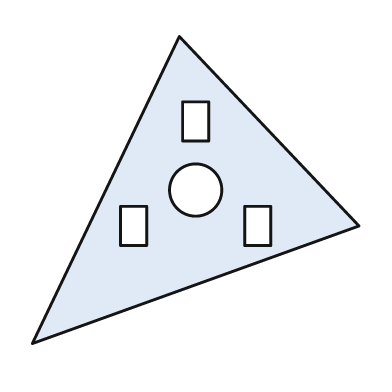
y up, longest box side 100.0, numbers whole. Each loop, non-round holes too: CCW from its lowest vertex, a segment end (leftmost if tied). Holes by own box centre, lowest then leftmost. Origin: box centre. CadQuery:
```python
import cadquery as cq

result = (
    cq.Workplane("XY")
    .moveTo(-50.0, -47.0)
    .lineTo(50.0, -11.0)
    .lineTo(-5.0, 47.0)
    .close()
    .moveTo(-23.0, -17.0)
    .lineTo(-15.0, -17.0)
    .lineTo(-15.0, -5.0)
    .lineTo(-23.0, -5.0)
    .close()
    .moveTo(15.0, -17.0)
    .lineTo(23.0, -17.0)
    .lineTo(23.0, -5.0)
    .lineTo(15.0, -5.0)
    .close()
    .moveTo(0.0, 0.0)
    .circle(8.0)
    .moveTo(-4.0, 15.0)
    .lineTo(4.0, 15.0)
    .lineTo(4.0, 27.0)
    .lineTo(-4.0, 27.0)
    .close()
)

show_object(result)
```